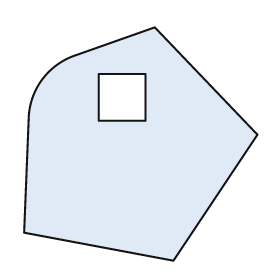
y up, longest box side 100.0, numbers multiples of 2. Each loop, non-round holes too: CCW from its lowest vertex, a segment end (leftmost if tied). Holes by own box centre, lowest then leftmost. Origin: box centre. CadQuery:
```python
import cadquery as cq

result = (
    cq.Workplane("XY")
    .moveTo(14.0, -50.0)
    .lineTo(50.0, 4.0)
    .lineTo(6.0, 50.0)
    .lineTo(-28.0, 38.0)
    .threePointArc((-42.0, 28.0), (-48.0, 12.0))
    .lineTo(-50.0, -38.0)
    .close()
    .moveTo(-18.0, 10.0)
    .lineTo(2.0, 10.0)
    .lineTo(2.0, 30.0)
    .lineTo(-18.0, 30.0)
    .close()
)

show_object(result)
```